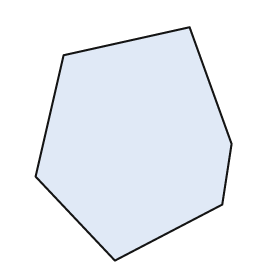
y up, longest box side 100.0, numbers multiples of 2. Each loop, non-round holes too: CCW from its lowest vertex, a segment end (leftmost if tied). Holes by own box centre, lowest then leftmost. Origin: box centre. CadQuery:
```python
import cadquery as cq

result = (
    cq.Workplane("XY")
    .moveTo(-8.0, -50.0)
    .lineTo(38.0, -26.0)
    .lineTo(42.0, 0.0)
    .lineTo(24.0, 50.0)
    .lineTo(-30.0, 38.0)
    .lineTo(-42.0, -14.0)
    .close()
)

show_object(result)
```